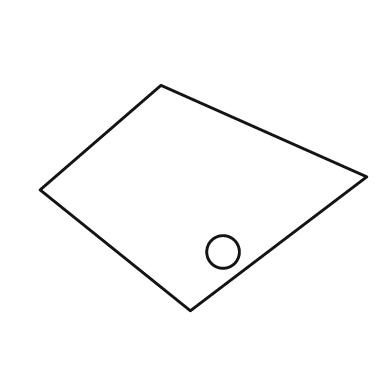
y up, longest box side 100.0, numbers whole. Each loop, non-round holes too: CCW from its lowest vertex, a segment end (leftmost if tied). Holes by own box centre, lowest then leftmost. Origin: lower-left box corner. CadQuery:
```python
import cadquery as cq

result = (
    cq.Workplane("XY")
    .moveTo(46.0, 0.0)
    .lineTo(100.0, 41.0)
    .lineTo(37.0, 69.0)
    .lineTo(0.0, 37.0)
    .close()
    .moveTo(56.0, 18.0)
    .circle(5.0)
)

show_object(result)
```